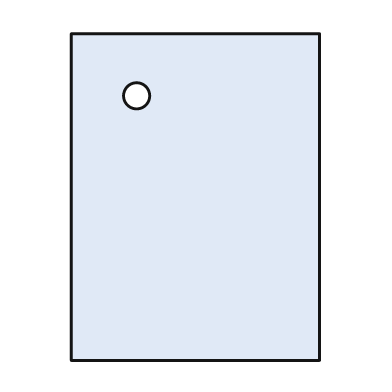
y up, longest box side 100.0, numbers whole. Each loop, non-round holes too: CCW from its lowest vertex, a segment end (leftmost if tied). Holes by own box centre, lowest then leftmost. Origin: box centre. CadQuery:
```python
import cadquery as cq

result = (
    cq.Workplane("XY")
    .moveTo(-38.0, -50.0)
    .lineTo(38.0, -50.0)
    .lineTo(38.0, 50.0)
    .lineTo(-38.0, 50.0)
    .close()
    .moveTo(-18.0, 31.0)
    .circle(4.0)
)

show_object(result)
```